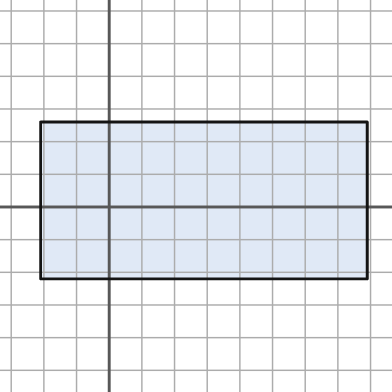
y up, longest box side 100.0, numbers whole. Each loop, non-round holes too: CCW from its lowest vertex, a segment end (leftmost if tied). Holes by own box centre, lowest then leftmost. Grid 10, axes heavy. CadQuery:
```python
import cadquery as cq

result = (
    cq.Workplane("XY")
    .moveTo(-21.0, -22.0)
    .lineTo(79.0, -22.0)
    .lineTo(79.0, 26.0)
    .lineTo(-21.0, 26.0)
    .close()
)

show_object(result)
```